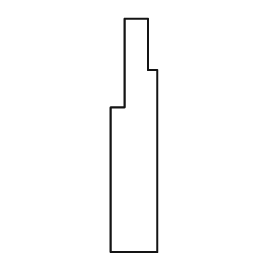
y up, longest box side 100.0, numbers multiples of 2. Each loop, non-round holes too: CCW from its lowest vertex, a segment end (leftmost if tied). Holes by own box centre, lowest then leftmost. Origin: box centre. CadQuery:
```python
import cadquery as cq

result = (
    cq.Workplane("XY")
    .moveTo(-10.0, -50.0)
    .lineTo(10.0, -50.0)
    .lineTo(10.0, 28.0)
    .lineTo(6.0, 28.0)
    .lineTo(6.0, 50.0)
    .lineTo(-4.0, 50.0)
    .lineTo(-4.0, 12.0)
    .lineTo(-10.0, 12.0)
    .close()
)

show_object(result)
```